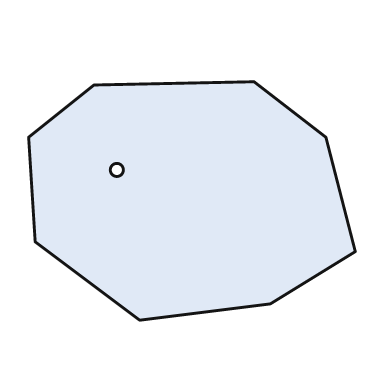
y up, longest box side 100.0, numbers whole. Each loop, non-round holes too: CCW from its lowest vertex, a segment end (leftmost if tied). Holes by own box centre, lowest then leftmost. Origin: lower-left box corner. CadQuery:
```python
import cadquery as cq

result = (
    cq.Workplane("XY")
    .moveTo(34.0, 0.0)
    .lineTo(74.0, 5.0)
    .lineTo(100.0, 21.0)
    .lineTo(91.0, 56.0)
    .lineTo(69.0, 73.0)
    .lineTo(20.0, 72.0)
    .lineTo(0.0, 56.0)
    .lineTo(2.0, 24.0)
    .close()
    .moveTo(27.0, 46.0)
    .circle(2.0)
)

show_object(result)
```